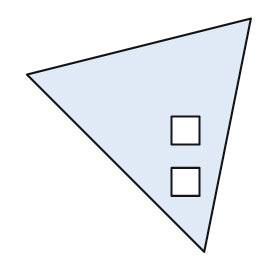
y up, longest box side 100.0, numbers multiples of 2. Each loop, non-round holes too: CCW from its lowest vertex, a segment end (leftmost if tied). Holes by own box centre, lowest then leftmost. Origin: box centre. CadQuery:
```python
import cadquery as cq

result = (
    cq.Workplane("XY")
    .moveTo(28.0, -50.0)
    .lineTo(48.0, 50.0)
    .lineTo(-48.0, 26.0)
    .close()
    .moveTo(14.0, -26.0)
    .lineTo(26.0, -26.0)
    .lineTo(26.0, -14.0)
    .lineTo(14.0, -14.0)
    .close()
    .moveTo(14.0, -4.0)
    .lineTo(26.0, -4.0)
    .lineTo(26.0, 8.0)
    .lineTo(14.0, 8.0)
    .close()
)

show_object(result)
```